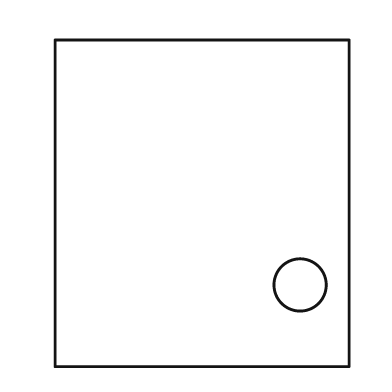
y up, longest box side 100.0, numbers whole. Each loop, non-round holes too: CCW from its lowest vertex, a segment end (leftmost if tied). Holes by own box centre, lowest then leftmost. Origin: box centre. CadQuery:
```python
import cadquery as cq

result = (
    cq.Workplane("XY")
    .moveTo(-45.0, -50.0)
    .lineTo(45.0, -50.0)
    .lineTo(45.0, 50.0)
    .lineTo(-45.0, 50.0)
    .close()
    .moveTo(30.0, -25.0)
    .circle(8.0)
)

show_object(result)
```